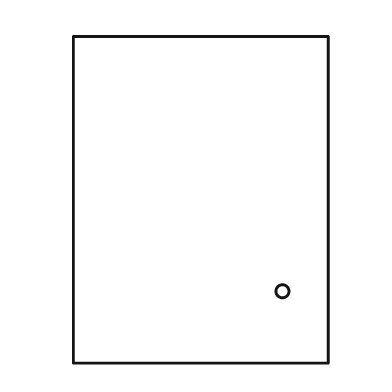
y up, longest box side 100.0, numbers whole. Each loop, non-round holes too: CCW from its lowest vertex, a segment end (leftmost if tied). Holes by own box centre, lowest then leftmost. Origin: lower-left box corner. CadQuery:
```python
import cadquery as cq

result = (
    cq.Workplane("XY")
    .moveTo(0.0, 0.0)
    .lineTo(78.0, 0.0)
    .lineTo(78.0, 100.0)
    .lineTo(0.0, 100.0)
    .close()
    .moveTo(64.0, 22.0)
    .circle(2.0)
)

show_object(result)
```